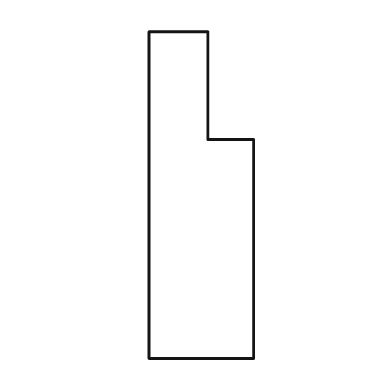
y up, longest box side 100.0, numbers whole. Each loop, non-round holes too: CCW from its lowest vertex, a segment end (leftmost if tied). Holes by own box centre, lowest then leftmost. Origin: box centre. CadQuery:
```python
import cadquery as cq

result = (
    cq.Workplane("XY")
    .moveTo(-16.0, -50.0)
    .lineTo(16.0, -50.0)
    .lineTo(16.0, 17.0)
    .lineTo(2.0, 17.0)
    .lineTo(2.0, 50.0)
    .lineTo(-16.0, 50.0)
    .close()
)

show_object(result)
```